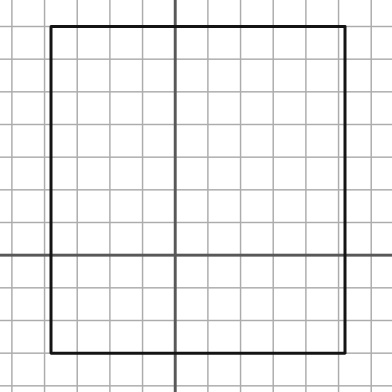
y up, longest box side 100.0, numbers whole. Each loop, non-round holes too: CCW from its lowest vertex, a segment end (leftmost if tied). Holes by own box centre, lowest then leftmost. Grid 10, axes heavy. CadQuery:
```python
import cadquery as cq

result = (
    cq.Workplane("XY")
    .moveTo(-38.0, -30.0)
    .lineTo(52.0, -30.0)
    .lineTo(52.0, 70.0)
    .lineTo(-38.0, 70.0)
    .close()
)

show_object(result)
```